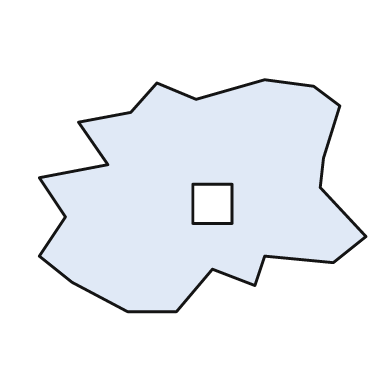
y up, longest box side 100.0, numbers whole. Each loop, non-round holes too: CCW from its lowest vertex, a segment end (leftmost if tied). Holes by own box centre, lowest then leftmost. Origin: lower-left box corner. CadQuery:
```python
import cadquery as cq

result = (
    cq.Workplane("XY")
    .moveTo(27.0, 0.0)
    .lineTo(42.0, 0.0)
    .lineTo(53.0, 13.0)
    .lineTo(66.0, 8.0)
    .lineTo(69.0, 17.0)
    .lineTo(90.0, 15.0)
    .lineTo(100.0, 23.0)
    .lineTo(86.0, 38.0)
    .lineTo(87.0, 47.0)
    .lineTo(92.0, 63.0)
    .lineTo(84.0, 69.0)
    .lineTo(69.0, 71.0)
    .lineTo(48.0, 65.0)
    .lineTo(36.0, 70.0)
    .lineTo(28.0, 61.0)
    .lineTo(12.0, 58.0)
    .lineTo(21.0, 45.0)
    .lineTo(0.0, 41.0)
    .lineTo(8.0, 29.0)
    .lineTo(0.0, 17.0)
    .lineTo(10.0, 9.0)
    .close()
    .moveTo(47.0, 27.0)
    .lineTo(59.0, 27.0)
    .lineTo(59.0, 39.0)
    .lineTo(47.0, 39.0)
    .close()
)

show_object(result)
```